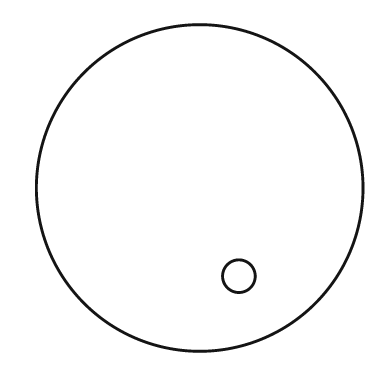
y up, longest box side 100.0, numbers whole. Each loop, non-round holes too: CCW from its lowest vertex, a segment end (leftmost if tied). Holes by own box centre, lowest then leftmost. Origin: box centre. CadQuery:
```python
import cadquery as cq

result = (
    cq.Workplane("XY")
    .moveTo(0.0, 0.0)
    .circle(50.0)
    .moveTo(12.0, -27.0)
    .circle(5.0)
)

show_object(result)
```